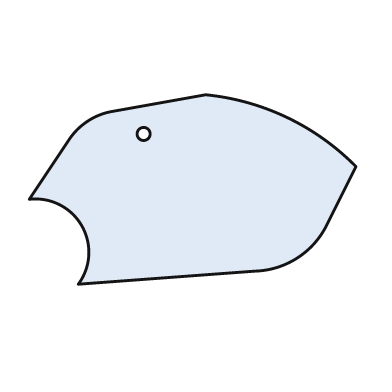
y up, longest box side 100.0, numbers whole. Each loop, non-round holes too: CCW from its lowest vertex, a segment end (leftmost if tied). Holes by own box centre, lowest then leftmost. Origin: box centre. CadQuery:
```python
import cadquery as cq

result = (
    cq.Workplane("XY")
    .moveTo(-35.0, -29.0)
    .lineTo(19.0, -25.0)
    .threePointArc((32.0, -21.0), (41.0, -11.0))
    .lineTo(50.0, 7.0)
    .threePointArc((29.0, 22.0), (4.0, 29.0))
    .lineTo(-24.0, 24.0)
    .threePointArc((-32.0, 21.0), (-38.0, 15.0))
    .lineTo(-50.0, -3.0)
    .threePointArc((-34.0, -11.0), (-35.0, -29.0))
    .close()
    .moveTo(-15.0, 17.0)
    .circle(2.0)
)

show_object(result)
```